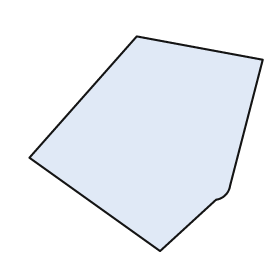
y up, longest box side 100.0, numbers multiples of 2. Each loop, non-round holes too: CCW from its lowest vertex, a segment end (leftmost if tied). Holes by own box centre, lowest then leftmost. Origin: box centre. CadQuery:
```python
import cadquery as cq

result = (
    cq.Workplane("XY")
    .moveTo(6.0, -46.0)
    .lineTo(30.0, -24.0)
    .threePointArc((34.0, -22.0), (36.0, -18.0))
    .lineTo(50.0, 36.0)
    .lineTo(-4.0, 46.0)
    .lineTo(-50.0, -6.0)
    .close()
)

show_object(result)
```